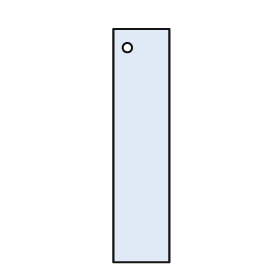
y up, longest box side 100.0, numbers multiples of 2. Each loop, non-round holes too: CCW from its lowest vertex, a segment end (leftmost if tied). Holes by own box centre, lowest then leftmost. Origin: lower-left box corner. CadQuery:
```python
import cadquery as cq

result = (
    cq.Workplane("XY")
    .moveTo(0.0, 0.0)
    .lineTo(24.0, 0.0)
    .lineTo(24.0, 100.0)
    .lineTo(0.0, 100.0)
    .close()
    .moveTo(6.0, 92.0)
    .circle(2.0)
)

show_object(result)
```